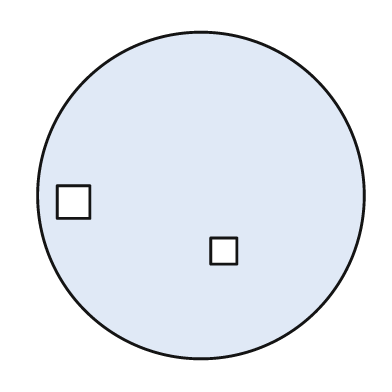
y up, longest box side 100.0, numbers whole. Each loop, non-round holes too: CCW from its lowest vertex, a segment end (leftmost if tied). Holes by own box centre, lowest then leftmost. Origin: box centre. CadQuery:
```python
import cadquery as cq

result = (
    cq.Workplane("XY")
    .moveTo(0.0, 0.0)
    .circle(50.0)
    .moveTo(3.0, -21.0)
    .lineTo(11.0, -21.0)
    .lineTo(11.0, -13.0)
    .lineTo(3.0, -13.0)
    .close()
    .moveTo(-44.0, -7.0)
    .lineTo(-34.0, -7.0)
    .lineTo(-34.0, 3.0)
    .lineTo(-44.0, 3.0)
    .close()
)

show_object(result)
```